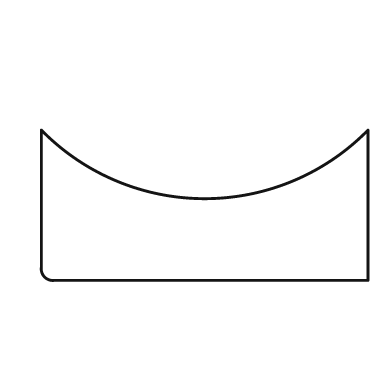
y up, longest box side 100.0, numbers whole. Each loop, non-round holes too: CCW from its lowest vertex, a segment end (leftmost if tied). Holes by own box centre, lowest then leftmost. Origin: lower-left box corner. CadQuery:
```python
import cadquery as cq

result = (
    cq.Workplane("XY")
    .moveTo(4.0, 0.0)
    .lineTo(100.0, 0.0)
    .lineTo(100.0, 46.0)
    .threePointArc((50.0, 25.0), (0.0, 46.0))
    .lineTo(0.0, 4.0)
    .threePointArc((1.0, 1.0), (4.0, 0.0))
    .close()
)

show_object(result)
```